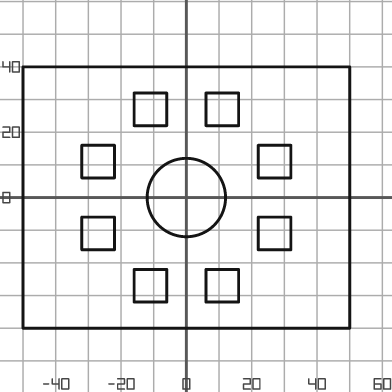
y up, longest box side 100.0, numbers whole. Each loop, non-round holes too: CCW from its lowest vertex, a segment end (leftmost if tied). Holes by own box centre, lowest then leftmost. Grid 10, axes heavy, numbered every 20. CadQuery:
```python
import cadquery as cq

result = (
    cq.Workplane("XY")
    .moveTo(-50.0, -40.0)
    .lineTo(50.0, -40.0)
    .lineTo(50.0, 40.0)
    .lineTo(-50.0, 40.0)
    .close()
    .moveTo(-16.0, -32.0)
    .lineTo(-6.0, -32.0)
    .lineTo(-6.0, -22.0)
    .lineTo(-16.0, -22.0)
    .close()
    .moveTo(6.0, -32.0)
    .lineTo(16.0, -32.0)
    .lineTo(16.0, -22.0)
    .lineTo(6.0, -22.0)
    .close()
    .moveTo(-32.0, -16.0)
    .lineTo(-22.0, -16.0)
    .lineTo(-22.0, -6.0)
    .lineTo(-32.0, -6.0)
    .close()
    .moveTo(22.0, -16.0)
    .lineTo(32.0, -16.0)
    .lineTo(32.0, -6.0)
    .lineTo(22.0, -6.0)
    .close()
    .moveTo(0.0, 0.0)
    .circle(12.0)
    .moveTo(-32.0, 6.0)
    .lineTo(-22.0, 6.0)
    .lineTo(-22.0, 16.0)
    .lineTo(-32.0, 16.0)
    .close()
    .moveTo(22.0, 6.0)
    .lineTo(32.0, 6.0)
    .lineTo(32.0, 16.0)
    .lineTo(22.0, 16.0)
    .close()
    .moveTo(-16.0, 22.0)
    .lineTo(-6.0, 22.0)
    .lineTo(-6.0, 32.0)
    .lineTo(-16.0, 32.0)
    .close()
    .moveTo(6.0, 22.0)
    .lineTo(16.0, 22.0)
    .lineTo(16.0, 32.0)
    .lineTo(6.0, 32.0)
    .close()
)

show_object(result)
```